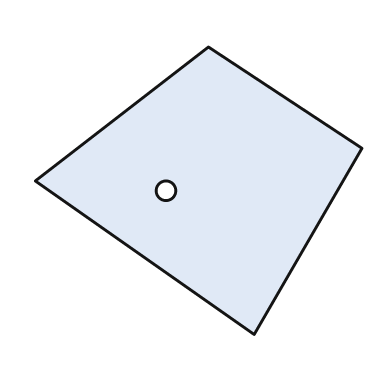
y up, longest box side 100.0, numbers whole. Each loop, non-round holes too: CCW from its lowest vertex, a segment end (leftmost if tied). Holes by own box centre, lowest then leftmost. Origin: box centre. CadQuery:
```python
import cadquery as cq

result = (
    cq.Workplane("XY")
    .moveTo(17.0, -44.0)
    .lineTo(50.0, 13.0)
    .lineTo(3.0, 44.0)
    .lineTo(-50.0, 3.0)
    .close()
    .moveTo(-10.0, 0.0)
    .circle(3.0)
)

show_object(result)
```